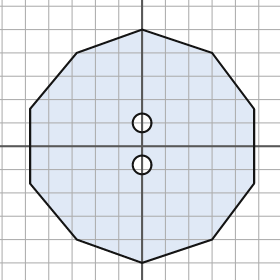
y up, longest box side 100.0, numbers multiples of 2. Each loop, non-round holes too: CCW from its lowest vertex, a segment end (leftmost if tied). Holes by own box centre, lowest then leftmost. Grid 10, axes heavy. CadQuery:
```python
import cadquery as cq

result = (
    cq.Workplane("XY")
    .moveTo(0.0, -50.0)
    .lineTo(30.0, -40.0)
    .lineTo(48.0, -16.0)
    .lineTo(48.0, 16.0)
    .lineTo(30.0, 40.0)
    .lineTo(0.0, 50.0)
    .lineTo(-28.0, 40.0)
    .lineTo(-48.0, 16.0)
    .lineTo(-48.0, -16.0)
    .lineTo(-28.0, -40.0)
    .close()
    .moveTo(0.0, -8.0)
    .circle(4.0)
    .moveTo(0.0, 10.0)
    .circle(4.0)
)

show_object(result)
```